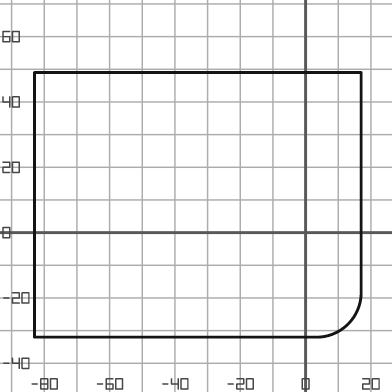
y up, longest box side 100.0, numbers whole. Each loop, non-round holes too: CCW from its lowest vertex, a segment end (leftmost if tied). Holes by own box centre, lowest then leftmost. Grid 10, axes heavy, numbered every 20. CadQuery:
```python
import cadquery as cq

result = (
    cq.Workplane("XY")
    .moveTo(-83.0, -32.0)
    .lineTo(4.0, -32.0)
    .threePointArc((13.0, -28.0), (17.0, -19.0))
    .lineTo(17.0, 49.0)
    .lineTo(-83.0, 49.0)
    .close()
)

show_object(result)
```